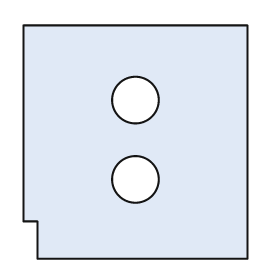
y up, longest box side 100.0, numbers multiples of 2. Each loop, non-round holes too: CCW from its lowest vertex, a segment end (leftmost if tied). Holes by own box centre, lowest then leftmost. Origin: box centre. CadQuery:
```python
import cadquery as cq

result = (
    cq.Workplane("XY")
    .moveTo(-42.0, -50.0)
    .lineTo(48.0, -50.0)
    .lineTo(48.0, 50.0)
    .lineTo(-48.0, 50.0)
    .lineTo(-48.0, -34.0)
    .lineTo(-42.0, -34.0)
    .close()
    .moveTo(0.0, -16.0)
    .circle(10.0)
    .moveTo(0.0, 18.0)
    .circle(10.0)
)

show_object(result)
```